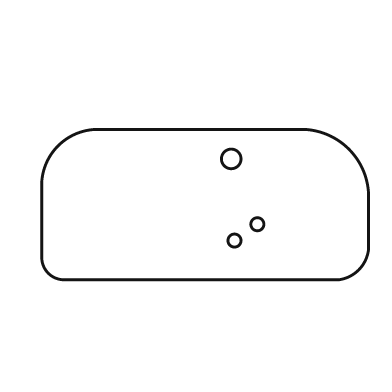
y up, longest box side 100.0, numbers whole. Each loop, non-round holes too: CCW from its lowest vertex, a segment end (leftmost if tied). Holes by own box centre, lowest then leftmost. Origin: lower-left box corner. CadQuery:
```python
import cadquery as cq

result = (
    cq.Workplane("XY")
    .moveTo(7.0, 0.0)
    .lineTo(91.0, 0.0)
    .threePointArc((97.0, 3.0), (100.0, 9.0))
    .lineTo(100.0, 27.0)
    .threePointArc((94.0, 40.0), (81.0, 46.0))
    .lineTo(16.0, 46.0)
    .threePointArc((5.0, 41.0), (0.0, 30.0))
    .lineTo(0.0, 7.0)
    .threePointArc((2.0, 2.0), (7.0, 0.0))
    .close()
    .moveTo(59.0, 12.0)
    .circle(2.0)
    .moveTo(66.0, 17.0)
    .circle(2.0)
    .moveTo(58.0, 37.0)
    .circle(3.0)
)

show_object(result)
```